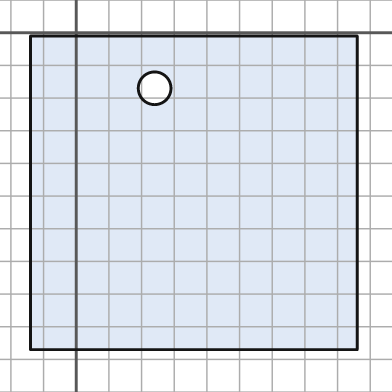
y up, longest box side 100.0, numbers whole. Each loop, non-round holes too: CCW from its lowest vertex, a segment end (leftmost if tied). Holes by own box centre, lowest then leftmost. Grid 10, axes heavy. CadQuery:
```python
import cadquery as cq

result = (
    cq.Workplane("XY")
    .moveTo(-14.0, -97.0)
    .lineTo(86.0, -97.0)
    .lineTo(86.0, -1.0)
    .lineTo(-14.0, -1.0)
    .close()
    .moveTo(24.0, -17.0)
    .circle(5.0)
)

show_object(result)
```